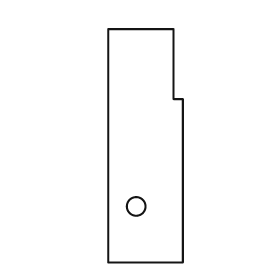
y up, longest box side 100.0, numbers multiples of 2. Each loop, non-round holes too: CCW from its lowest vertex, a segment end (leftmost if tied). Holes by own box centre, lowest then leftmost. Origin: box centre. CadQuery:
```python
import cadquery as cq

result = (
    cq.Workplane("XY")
    .moveTo(-16.0, -50.0)
    .lineTo(16.0, -50.0)
    .lineTo(16.0, 20.0)
    .lineTo(12.0, 20.0)
    .lineTo(12.0, 50.0)
    .lineTo(-16.0, 50.0)
    .close()
    .moveTo(-4.0, -26.0)
    .circle(4.0)
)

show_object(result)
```